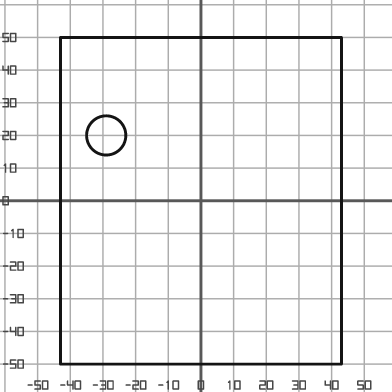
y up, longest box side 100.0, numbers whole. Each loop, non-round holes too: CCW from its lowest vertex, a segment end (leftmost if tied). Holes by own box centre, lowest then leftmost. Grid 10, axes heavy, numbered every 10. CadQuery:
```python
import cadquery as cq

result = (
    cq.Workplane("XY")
    .moveTo(-43.0, -50.0)
    .lineTo(43.0, -50.0)
    .lineTo(43.0, 50.0)
    .lineTo(-43.0, 50.0)
    .close()
    .moveTo(-29.0, 20.0)
    .circle(6.0)
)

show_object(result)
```